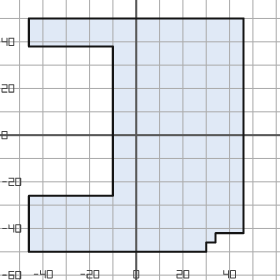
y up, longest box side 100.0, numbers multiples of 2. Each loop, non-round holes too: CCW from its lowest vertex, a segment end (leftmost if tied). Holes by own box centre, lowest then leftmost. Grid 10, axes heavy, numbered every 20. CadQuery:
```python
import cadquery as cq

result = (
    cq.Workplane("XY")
    .moveTo(-46.0, -50.0)
    .lineTo(30.0, -50.0)
    .lineTo(30.0, -46.0)
    .lineTo(34.0, -46.0)
    .lineTo(34.0, -42.0)
    .lineTo(46.0, -42.0)
    .lineTo(46.0, 50.0)
    .lineTo(-46.0, 50.0)
    .lineTo(-46.0, 38.0)
    .lineTo(-10.0, 38.0)
    .lineTo(-10.0, -26.0)
    .lineTo(-46.0, -26.0)
    .close()
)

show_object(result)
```